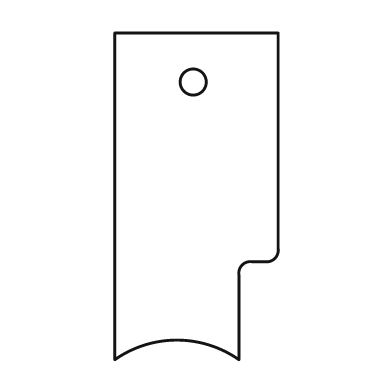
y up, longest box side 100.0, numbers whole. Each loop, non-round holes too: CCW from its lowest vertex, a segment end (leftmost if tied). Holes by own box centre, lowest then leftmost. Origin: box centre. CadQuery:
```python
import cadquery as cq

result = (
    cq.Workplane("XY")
    .moveTo(-25.0, -50.0)
    .threePointArc((-6.0, -44.0), (13.0, -50.0))
    .lineTo(13.0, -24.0)
    .threePointArc((14.0, -21.0), (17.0, -20.0))
    .lineTo(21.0, -20.0)
    .threePointArc((24.0, -19.0), (25.0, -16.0))
    .lineTo(25.0, 50.0)
    .lineTo(-25.0, 50.0)
    .close()
    .moveTo(-1.0, 35.0)
    .circle(4.0)
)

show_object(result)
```